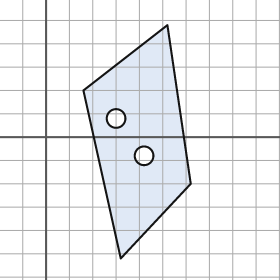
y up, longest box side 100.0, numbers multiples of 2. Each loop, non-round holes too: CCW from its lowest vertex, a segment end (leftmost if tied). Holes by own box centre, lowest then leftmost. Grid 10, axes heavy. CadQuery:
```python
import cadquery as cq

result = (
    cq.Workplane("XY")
    .moveTo(32.0, -52.0)
    .lineTo(62.0, -20.0)
    .lineTo(52.0, 48.0)
    .lineTo(16.0, 20.0)
    .close()
    .moveTo(42.0, -8.0)
    .circle(4.0)
    .moveTo(30.0, 8.0)
    .circle(4.0)
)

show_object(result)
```